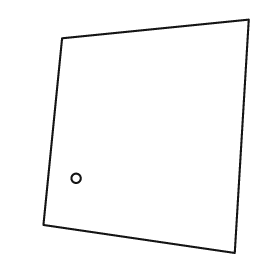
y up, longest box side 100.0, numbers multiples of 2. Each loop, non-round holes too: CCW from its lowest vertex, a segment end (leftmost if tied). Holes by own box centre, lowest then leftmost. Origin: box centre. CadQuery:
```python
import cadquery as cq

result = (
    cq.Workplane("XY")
    .moveTo(38.0, -50.0)
    .lineTo(44.0, 50.0)
    .lineTo(-36.0, 42.0)
    .lineTo(-44.0, -38.0)
    .close()
    .moveTo(-30.0, -18.0)
    .circle(2.0)
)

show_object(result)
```